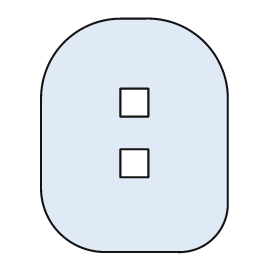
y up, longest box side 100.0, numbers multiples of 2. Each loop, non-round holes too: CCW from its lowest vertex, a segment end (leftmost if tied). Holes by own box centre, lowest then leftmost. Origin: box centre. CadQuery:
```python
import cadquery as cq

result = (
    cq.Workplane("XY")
    .moveTo(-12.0, -50.0)
    .lineTo(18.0, -50.0)
    .threePointArc((34.0, -44.0), (40.0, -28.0))
    .lineTo(40.0, 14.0)
    .threePointArc((30.0, 40.0), (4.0, 50.0))
    .lineTo(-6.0, 50.0)
    .threePointArc((-30.0, 40.0), (-40.0, 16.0))
    .lineTo(-40.0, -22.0)
    .threePointArc((-32.0, -42.0), (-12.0, -50.0))
    .close()
    .moveTo(-6.0, -18.0)
    .lineTo(6.0, -18.0)
    .lineTo(6.0, -6.0)
    .lineTo(-6.0, -6.0)
    .close()
    .moveTo(-6.0, 8.0)
    .lineTo(6.0, 8.0)
    .lineTo(6.0, 20.0)
    .lineTo(-6.0, 20.0)
    .close()
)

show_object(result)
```